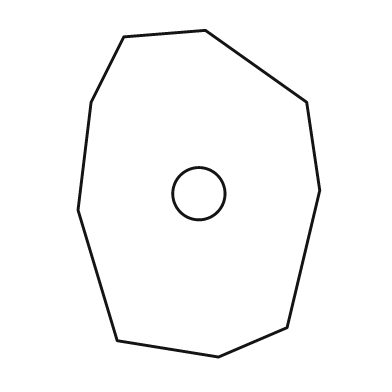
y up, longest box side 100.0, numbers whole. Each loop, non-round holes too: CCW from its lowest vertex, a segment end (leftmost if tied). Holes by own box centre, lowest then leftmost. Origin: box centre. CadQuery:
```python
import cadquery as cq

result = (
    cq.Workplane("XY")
    .moveTo(6.0, -50.0)
    .lineTo(27.0, -41.0)
    .lineTo(37.0, 1.0)
    .lineTo(33.0, 28.0)
    .lineTo(2.0, 50.0)
    .lineTo(-23.0, 48.0)
    .lineTo(-33.0, 28.0)
    .lineTo(-37.0, -5.0)
    .lineTo(-25.0, -45.0)
    .close()
    .moveTo(0.0, 0.0)
    .circle(8.0)
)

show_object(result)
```